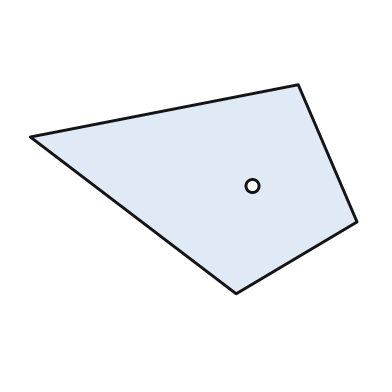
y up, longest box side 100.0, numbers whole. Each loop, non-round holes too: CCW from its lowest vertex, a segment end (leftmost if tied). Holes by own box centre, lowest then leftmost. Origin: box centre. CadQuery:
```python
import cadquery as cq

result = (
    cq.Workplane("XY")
    .moveTo(13.0, -32.0)
    .lineTo(50.0, -10.0)
    .lineTo(32.0, 32.0)
    .lineTo(-50.0, 16.0)
    .close()
    .moveTo(18.0, 1.0)
    .circle(2.0)
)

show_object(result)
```